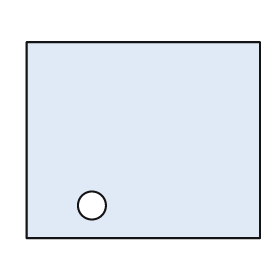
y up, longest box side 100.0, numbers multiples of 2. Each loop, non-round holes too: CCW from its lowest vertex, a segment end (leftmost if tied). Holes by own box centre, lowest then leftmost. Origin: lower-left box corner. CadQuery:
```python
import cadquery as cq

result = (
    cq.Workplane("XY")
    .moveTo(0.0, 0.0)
    .lineTo(100.0, 0.0)
    .lineTo(100.0, 84.0)
    .lineTo(0.0, 84.0)
    .close()
    .moveTo(28.0, 14.0)
    .circle(6.0)
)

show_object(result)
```